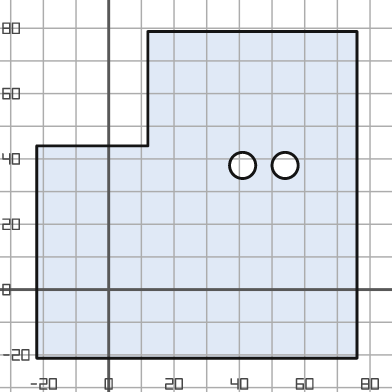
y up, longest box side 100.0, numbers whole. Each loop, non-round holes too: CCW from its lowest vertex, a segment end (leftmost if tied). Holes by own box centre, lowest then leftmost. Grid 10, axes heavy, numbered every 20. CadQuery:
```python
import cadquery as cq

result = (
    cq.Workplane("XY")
    .moveTo(-22.0, -21.0)
    .lineTo(76.0, -21.0)
    .lineTo(76.0, 79.0)
    .lineTo(12.0, 79.0)
    .lineTo(12.0, 44.0)
    .lineTo(-22.0, 44.0)
    .close()
    .moveTo(41.0, 38.0)
    .circle(4.0)
    .moveTo(54.0, 38.0)
    .circle(4.0)
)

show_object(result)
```